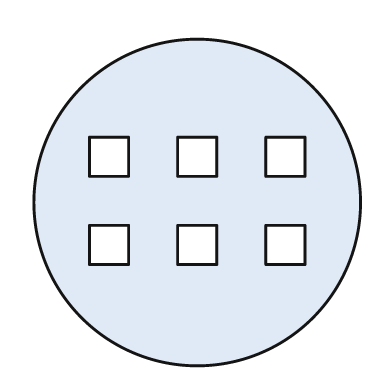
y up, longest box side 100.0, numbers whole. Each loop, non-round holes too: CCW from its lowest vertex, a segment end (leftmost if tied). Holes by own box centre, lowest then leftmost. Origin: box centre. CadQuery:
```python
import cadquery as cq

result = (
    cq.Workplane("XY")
    .moveTo(0.0, 0.0)
    .circle(50.0)
    .moveTo(-33.0, -19.0)
    .lineTo(-21.0, -19.0)
    .lineTo(-21.0, -7.0)
    .lineTo(-33.0, -7.0)
    .close()
    .moveTo(-6.0, -19.0)
    .lineTo(6.0, -19.0)
    .lineTo(6.0, -7.0)
    .lineTo(-6.0, -7.0)
    .close()
    .moveTo(21.0, -19.0)
    .lineTo(33.0, -19.0)
    .lineTo(33.0, -7.0)
    .lineTo(21.0, -7.0)
    .close()
    .moveTo(-33.0, 8.0)
    .lineTo(-21.0, 8.0)
    .lineTo(-21.0, 20.0)
    .lineTo(-33.0, 20.0)
    .close()
    .moveTo(-6.0, 8.0)
    .lineTo(6.0, 8.0)
    .lineTo(6.0, 20.0)
    .lineTo(-6.0, 20.0)
    .close()
    .moveTo(21.0, 8.0)
    .lineTo(33.0, 8.0)
    .lineTo(33.0, 20.0)
    .lineTo(21.0, 20.0)
    .close()
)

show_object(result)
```